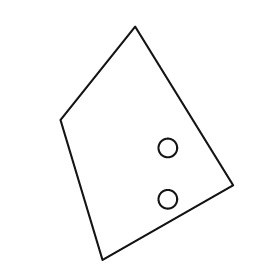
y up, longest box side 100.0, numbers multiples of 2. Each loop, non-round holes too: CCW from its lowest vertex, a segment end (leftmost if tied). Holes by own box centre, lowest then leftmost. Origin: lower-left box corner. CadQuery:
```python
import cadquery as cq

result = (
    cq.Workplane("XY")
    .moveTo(18.0, 0.0)
    .lineTo(74.0, 32.0)
    .lineTo(32.0, 100.0)
    .lineTo(0.0, 60.0)
    .close()
    .moveTo(46.0, 26.0)
    .circle(4.0)
    .moveTo(46.0, 48.0)
    .circle(4.0)
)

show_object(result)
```